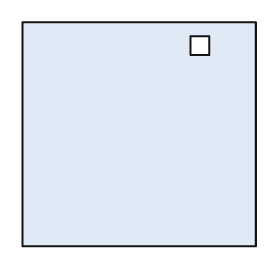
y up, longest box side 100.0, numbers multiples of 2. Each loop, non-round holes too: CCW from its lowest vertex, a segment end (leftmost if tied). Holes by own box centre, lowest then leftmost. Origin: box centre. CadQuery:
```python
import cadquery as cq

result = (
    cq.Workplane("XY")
    .moveTo(-50.0, -48.0)
    .lineTo(50.0, -48.0)
    .lineTo(50.0, 48.0)
    .lineTo(-50.0, 48.0)
    .close()
    .moveTo(22.0, 34.0)
    .lineTo(30.0, 34.0)
    .lineTo(30.0, 42.0)
    .lineTo(22.0, 42.0)
    .close()
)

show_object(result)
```